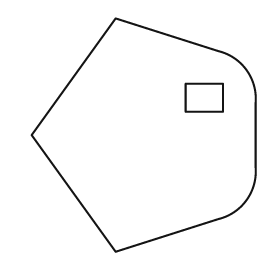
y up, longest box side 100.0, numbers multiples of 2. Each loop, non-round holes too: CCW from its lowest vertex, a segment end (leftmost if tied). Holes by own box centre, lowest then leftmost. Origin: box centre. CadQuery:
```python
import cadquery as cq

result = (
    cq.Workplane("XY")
    .moveTo(-12.0, -50.0)
    .lineTo(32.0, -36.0)
    .threePointArc((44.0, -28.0), (48.0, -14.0))
    .lineTo(48.0, 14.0)
    .threePointArc((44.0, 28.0), (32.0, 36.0))
    .lineTo(-12.0, 50.0)
    .lineTo(-48.0, 0.0)
    .close()
    .moveTo(18.0, 10.0)
    .lineTo(34.0, 10.0)
    .lineTo(34.0, 22.0)
    .lineTo(18.0, 22.0)
    .close()
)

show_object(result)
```